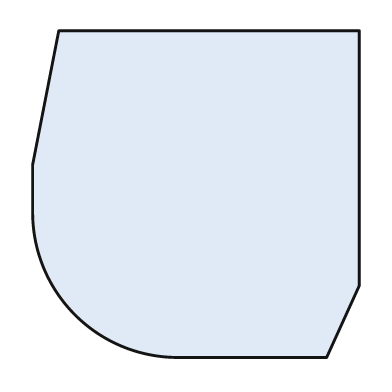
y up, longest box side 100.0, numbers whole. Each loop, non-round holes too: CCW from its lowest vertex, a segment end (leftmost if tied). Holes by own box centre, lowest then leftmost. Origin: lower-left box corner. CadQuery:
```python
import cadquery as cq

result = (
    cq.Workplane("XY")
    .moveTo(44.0, 0.0)
    .lineTo(90.0, 0.0)
    .lineTo(100.0, 22.0)
    .lineTo(100.0, 100.0)
    .lineTo(8.0, 100.0)
    .lineTo(0.0, 59.0)
    .lineTo(0.0, 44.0)
    .threePointArc((13.0, 13.0), (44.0, 0.0))
    .close()
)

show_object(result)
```